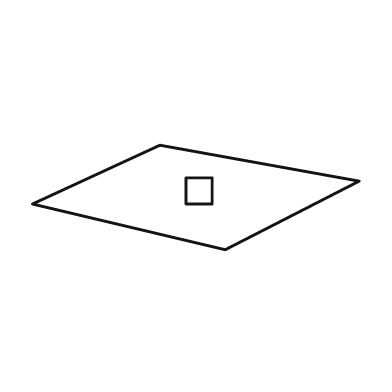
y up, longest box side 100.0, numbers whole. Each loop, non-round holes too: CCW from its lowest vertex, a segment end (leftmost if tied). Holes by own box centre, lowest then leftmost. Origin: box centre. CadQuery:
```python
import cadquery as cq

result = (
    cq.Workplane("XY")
    .moveTo(9.0, -16.0)
    .lineTo(50.0, 5.0)
    .lineTo(-11.0, 16.0)
    .lineTo(-50.0, -2.0)
    .close()
    .moveTo(-3.0, -2.0)
    .lineTo(5.0, -2.0)
    .lineTo(5.0, 6.0)
    .lineTo(-3.0, 6.0)
    .close()
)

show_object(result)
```